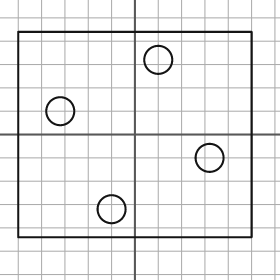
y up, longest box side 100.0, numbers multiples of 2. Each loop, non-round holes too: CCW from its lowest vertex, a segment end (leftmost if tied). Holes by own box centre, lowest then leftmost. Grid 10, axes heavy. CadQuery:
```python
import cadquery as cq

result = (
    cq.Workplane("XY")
    .moveTo(-50.0, -44.0)
    .lineTo(50.0, -44.0)
    .lineTo(50.0, 44.0)
    .lineTo(-50.0, 44.0)
    .close()
    .moveTo(-10.0, -32.0)
    .circle(6.0)
    .moveTo(32.0, -10.0)
    .circle(6.0)
    .moveTo(-32.0, 10.0)
    .circle(6.0)
    .moveTo(10.0, 32.0)
    .circle(6.0)
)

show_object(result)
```